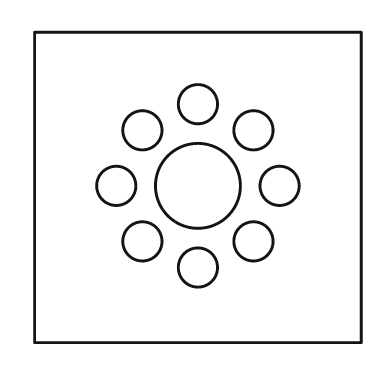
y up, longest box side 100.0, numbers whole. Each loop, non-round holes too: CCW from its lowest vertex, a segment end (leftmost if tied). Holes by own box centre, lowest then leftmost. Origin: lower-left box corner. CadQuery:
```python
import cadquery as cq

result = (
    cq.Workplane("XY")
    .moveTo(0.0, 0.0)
    .lineTo(100.0, 0.0)
    .lineTo(100.0, 95.0)
    .lineTo(0.0, 95.0)
    .close()
    .moveTo(50.0, 23.0)
    .circle(6.0)
    .moveTo(33.0, 31.0)
    .circle(6.0)
    .moveTo(67.0, 31.0)
    .circle(6.0)
    .moveTo(25.0, 48.0)
    .circle(6.0)
    .moveTo(50.0, 48.0)
    .circle(13.0)
    .moveTo(75.0, 48.0)
    .circle(6.0)
    .moveTo(33.0, 65.0)
    .circle(6.0)
    .moveTo(67.0, 65.0)
    .circle(6.0)
    .moveTo(50.0, 73.0)
    .circle(6.0)
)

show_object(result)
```